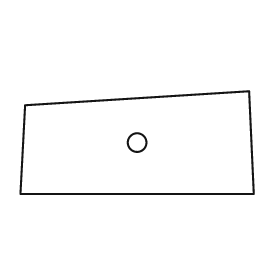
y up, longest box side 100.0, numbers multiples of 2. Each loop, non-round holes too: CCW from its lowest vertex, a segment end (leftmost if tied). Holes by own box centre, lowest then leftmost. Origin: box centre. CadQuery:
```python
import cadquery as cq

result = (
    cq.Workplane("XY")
    .moveTo(-50.0, -22.0)
    .lineTo(50.0, -22.0)
    .lineTo(48.0, 22.0)
    .lineTo(-48.0, 16.0)
    .close()
    .moveTo(0.0, 0.0)
    .circle(4.0)
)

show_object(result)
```